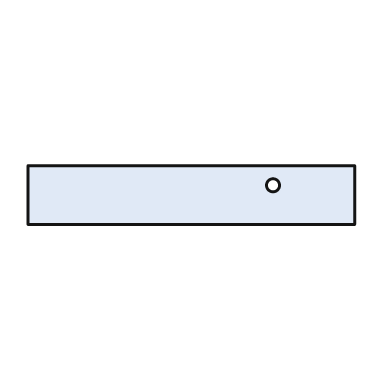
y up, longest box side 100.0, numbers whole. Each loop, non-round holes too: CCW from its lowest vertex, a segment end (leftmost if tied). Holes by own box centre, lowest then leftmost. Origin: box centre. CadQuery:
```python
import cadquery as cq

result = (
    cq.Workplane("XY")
    .moveTo(-50.0, -9.0)
    .lineTo(50.0, -9.0)
    .lineTo(50.0, 9.0)
    .lineTo(-50.0, 9.0)
    .close()
    .moveTo(25.0, 3.0)
    .circle(2.0)
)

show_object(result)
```